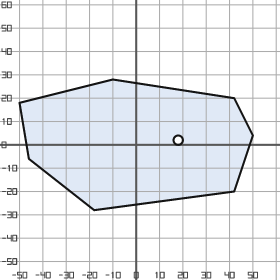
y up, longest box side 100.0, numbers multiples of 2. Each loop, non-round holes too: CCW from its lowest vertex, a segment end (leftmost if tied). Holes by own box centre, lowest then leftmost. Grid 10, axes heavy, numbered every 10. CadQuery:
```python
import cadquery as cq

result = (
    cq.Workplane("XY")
    .moveTo(-18.0, -28.0)
    .lineTo(42.0, -20.0)
    .lineTo(50.0, 4.0)
    .lineTo(42.0, 20.0)
    .lineTo(-10.0, 28.0)
    .lineTo(-50.0, 18.0)
    .lineTo(-46.0, -6.0)
    .close()
    .moveTo(18.0, 2.0)
    .circle(2.0)
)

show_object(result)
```